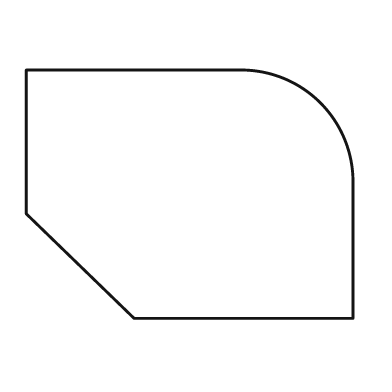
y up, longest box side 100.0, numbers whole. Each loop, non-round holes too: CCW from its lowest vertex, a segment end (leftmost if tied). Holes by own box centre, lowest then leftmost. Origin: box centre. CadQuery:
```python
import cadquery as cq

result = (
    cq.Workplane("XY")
    .moveTo(-17.0, -38.0)
    .lineTo(50.0, -38.0)
    .lineTo(50.0, 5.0)
    .threePointArc((40.0, 28.0), (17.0, 38.0))
    .lineTo(-50.0, 38.0)
    .lineTo(-50.0, -6.0)
    .close()
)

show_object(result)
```